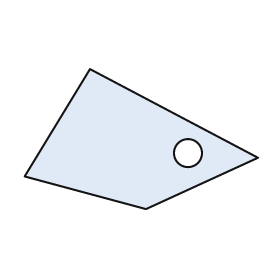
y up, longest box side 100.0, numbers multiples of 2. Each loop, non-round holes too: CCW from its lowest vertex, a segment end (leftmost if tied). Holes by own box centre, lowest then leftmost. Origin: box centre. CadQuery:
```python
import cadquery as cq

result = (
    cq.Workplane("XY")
    .moveTo(2.0, -30.0)
    .lineTo(50.0, -8.0)
    .lineTo(-22.0, 30.0)
    .lineTo(-50.0, -16.0)
    .close()
    .moveTo(20.0, -6.0)
    .circle(6.0)
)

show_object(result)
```